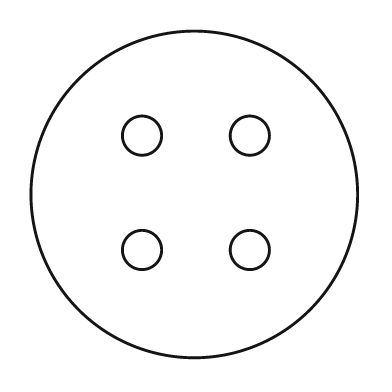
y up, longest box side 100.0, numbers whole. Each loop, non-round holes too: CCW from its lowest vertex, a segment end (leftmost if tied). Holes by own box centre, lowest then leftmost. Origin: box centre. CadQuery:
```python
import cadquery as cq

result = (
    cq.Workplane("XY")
    .moveTo(0.0, 0.0)
    .circle(50.0)
    .moveTo(-16.0, -17.0)
    .circle(6.0)
    .moveTo(17.0, -17.0)
    .circle(6.0)
    .moveTo(-16.0, 18.0)
    .circle(6.0)
    .moveTo(17.0, 18.0)
    .circle(6.0)
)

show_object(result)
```